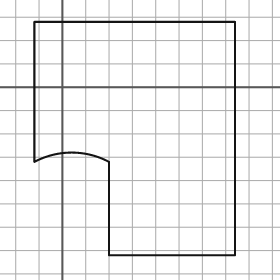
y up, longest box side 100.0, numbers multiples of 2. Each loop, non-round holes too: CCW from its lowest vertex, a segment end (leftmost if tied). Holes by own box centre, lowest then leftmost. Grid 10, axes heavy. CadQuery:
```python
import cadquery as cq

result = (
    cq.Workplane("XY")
    .moveTo(20.0, -72.0)
    .lineTo(74.0, -72.0)
    .lineTo(74.0, 28.0)
    .lineTo(-12.0, 28.0)
    .lineTo(-12.0, -32.0)
    .threePointArc((4.0, -28.0), (20.0, -32.0))
    .close()
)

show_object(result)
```